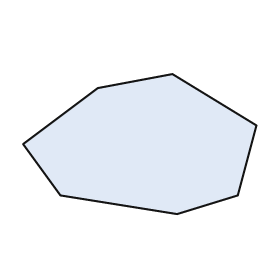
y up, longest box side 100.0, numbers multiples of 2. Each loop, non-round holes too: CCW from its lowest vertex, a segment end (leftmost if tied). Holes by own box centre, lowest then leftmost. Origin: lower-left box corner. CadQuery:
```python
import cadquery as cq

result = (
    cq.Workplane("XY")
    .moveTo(66.0, 0.0)
    .lineTo(92.0, 8.0)
    .lineTo(100.0, 38.0)
    .lineTo(64.0, 60.0)
    .lineTo(32.0, 54.0)
    .lineTo(0.0, 30.0)
    .lineTo(16.0, 8.0)
    .close()
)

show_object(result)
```